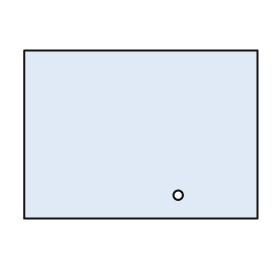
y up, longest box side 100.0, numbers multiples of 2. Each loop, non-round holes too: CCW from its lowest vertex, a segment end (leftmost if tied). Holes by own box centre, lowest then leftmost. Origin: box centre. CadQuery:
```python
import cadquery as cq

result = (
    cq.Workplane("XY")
    .moveTo(-50.0, -36.0)
    .lineTo(50.0, -36.0)
    .lineTo(50.0, 36.0)
    .lineTo(-50.0, 36.0)
    .close()
    .moveTo(16.0, -26.0)
    .circle(2.0)
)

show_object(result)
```